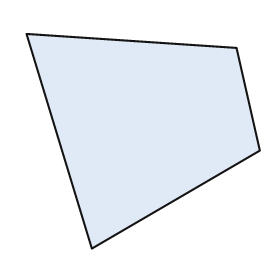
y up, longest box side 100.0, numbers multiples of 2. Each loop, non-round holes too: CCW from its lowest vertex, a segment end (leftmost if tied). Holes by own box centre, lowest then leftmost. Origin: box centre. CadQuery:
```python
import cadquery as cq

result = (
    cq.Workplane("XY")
    .moveTo(-22.0, -46.0)
    .lineTo(50.0, -4.0)
    .lineTo(40.0, 40.0)
    .lineTo(-50.0, 46.0)
    .close()
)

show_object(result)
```